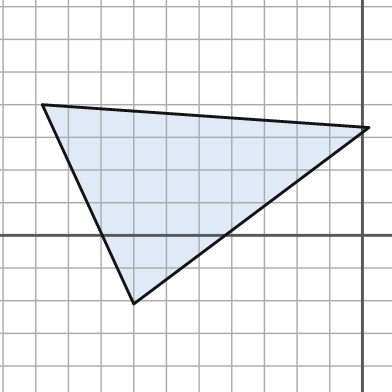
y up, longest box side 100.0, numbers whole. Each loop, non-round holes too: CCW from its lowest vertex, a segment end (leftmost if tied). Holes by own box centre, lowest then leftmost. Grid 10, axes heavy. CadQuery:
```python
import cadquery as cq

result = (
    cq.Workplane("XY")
    .moveTo(-70.0, -21.0)
    .lineTo(2.0, 33.0)
    .lineTo(-98.0, 40.0)
    .close()
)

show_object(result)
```